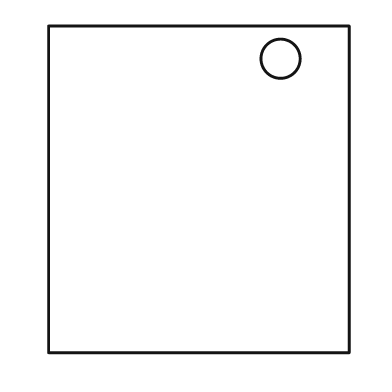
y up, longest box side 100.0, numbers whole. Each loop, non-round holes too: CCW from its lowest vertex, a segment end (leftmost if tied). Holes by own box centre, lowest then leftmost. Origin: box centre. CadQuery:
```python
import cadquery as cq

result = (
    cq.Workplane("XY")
    .moveTo(-46.0, -50.0)
    .lineTo(46.0, -50.0)
    .lineTo(46.0, 50.0)
    .lineTo(-46.0, 50.0)
    .close()
    .moveTo(25.0, 40.0)
    .circle(6.0)
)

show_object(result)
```